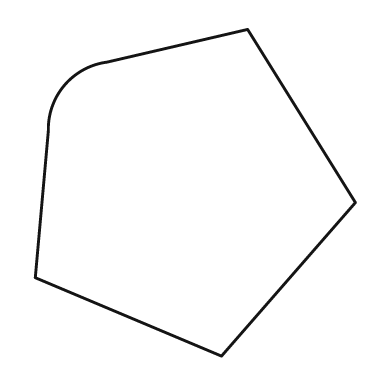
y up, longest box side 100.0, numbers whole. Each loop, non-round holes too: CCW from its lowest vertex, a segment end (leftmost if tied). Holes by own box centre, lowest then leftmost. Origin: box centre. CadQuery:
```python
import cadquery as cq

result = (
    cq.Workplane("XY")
    .moveTo(8.0, -50.0)
    .lineTo(49.0, -3.0)
    .lineTo(16.0, 50.0)
    .lineTo(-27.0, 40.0)
    .threePointArc((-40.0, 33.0), (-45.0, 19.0))
    .lineTo(-49.0, -26.0)
    .close()
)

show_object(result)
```